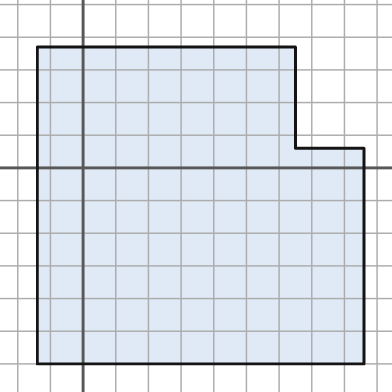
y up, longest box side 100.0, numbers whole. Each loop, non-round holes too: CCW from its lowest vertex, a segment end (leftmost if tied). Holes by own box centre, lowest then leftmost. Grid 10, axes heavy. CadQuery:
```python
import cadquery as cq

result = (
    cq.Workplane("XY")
    .moveTo(-14.0, -60.0)
    .lineTo(86.0, -60.0)
    .lineTo(86.0, 6.0)
    .lineTo(65.0, 6.0)
    .lineTo(65.0, 37.0)
    .lineTo(-14.0, 37.0)
    .close()
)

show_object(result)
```